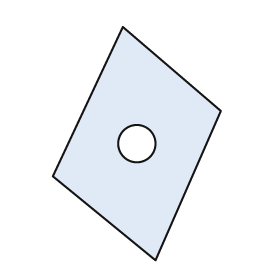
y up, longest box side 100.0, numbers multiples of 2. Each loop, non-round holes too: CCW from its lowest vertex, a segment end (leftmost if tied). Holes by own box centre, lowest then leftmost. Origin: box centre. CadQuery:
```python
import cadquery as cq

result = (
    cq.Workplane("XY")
    .moveTo(8.0, -50.0)
    .lineTo(36.0, 14.0)
    .lineTo(-6.0, 50.0)
    .lineTo(-36.0, -14.0)
    .close()
    .moveTo(0.0, 0.0)
    .circle(8.0)
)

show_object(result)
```